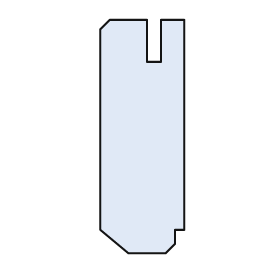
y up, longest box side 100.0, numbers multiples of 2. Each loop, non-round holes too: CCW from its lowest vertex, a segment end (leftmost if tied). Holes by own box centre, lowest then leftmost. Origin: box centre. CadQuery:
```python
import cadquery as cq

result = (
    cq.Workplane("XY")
    .moveTo(-6.0, -50.0)
    .lineTo(10.0, -50.0)
    .lineTo(14.0, -46.0)
    .lineTo(14.0, -40.0)
    .lineTo(18.0, -40.0)
    .lineTo(18.0, 50.0)
    .lineTo(8.0, 50.0)
    .lineTo(8.0, 32.0)
    .lineTo(2.0, 32.0)
    .lineTo(2.0, 50.0)
    .lineTo(-14.0, 50.0)
    .lineTo(-18.0, 46.0)
    .lineTo(-18.0, -40.0)
    .close()
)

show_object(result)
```